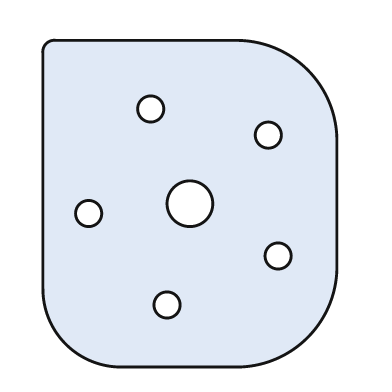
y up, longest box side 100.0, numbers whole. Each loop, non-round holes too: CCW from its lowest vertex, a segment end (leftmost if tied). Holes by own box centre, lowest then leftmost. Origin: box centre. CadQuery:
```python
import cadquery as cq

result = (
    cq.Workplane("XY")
    .moveTo(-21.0, -50.0)
    .lineTo(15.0, -50.0)
    .threePointArc((36.0, -41.0), (45.0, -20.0))
    .lineTo(45.0, 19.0)
    .threePointArc((36.0, 41.0), (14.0, 50.0))
    .lineTo(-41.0, 50.0)
    .threePointArc((-44.0, 49.0), (-45.0, 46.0))
    .lineTo(-45.0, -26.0)
    .threePointArc((-38.0, -43.0), (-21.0, -50.0))
    .close()
    .moveTo(-7.0, -31.0)
    .circle(4.0)
    .moveTo(27.0, -16.0)
    .circle(4.0)
    .moveTo(-31.0, -3.0)
    .circle(4.0)
    .moveTo(0.0, 0.0)
    .circle(7.0)
    .moveTo(24.0, 21.0)
    .circle(4.0)
    .moveTo(-12.0, 29.0)
    .circle(4.0)
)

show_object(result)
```